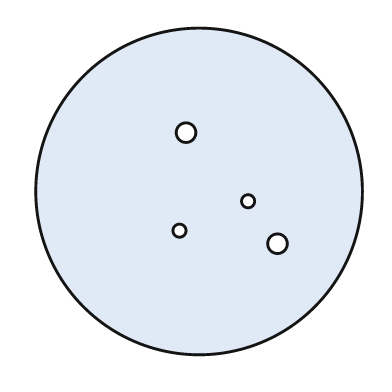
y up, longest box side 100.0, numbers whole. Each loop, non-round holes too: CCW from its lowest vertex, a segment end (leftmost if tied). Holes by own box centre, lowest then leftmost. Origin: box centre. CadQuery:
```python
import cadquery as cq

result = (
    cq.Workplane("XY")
    .moveTo(0.0, 0.0)
    .circle(50.0)
    .moveTo(24.0, -16.0)
    .circle(3.0)
    .moveTo(-6.0, -12.0)
    .circle(2.0)
    .moveTo(15.0, -3.0)
    .circle(2.0)
    .moveTo(-4.0, 18.0)
    .circle(3.0)
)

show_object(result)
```